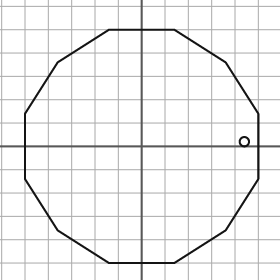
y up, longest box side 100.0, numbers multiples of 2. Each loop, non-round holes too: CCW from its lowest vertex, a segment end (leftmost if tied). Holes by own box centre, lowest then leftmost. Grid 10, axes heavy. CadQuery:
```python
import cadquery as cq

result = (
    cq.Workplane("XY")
    .moveTo(-14.0, -50.0)
    .lineTo(14.0, -50.0)
    .lineTo(36.0, -36.0)
    .lineTo(50.0, -14.0)
    .lineTo(50.0, 14.0)
    .lineTo(36.0, 36.0)
    .lineTo(14.0, 50.0)
    .lineTo(-14.0, 50.0)
    .lineTo(-36.0, 36.0)
    .lineTo(-50.0, 14.0)
    .lineTo(-50.0, -14.0)
    .lineTo(-36.0, -36.0)
    .close()
    .moveTo(44.0, 2.0)
    .circle(2.0)
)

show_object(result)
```